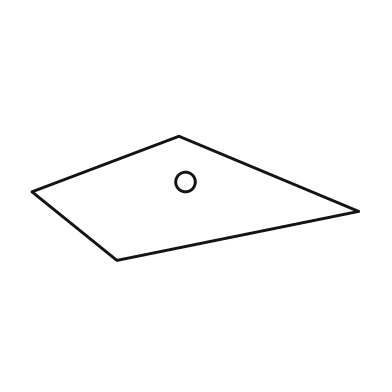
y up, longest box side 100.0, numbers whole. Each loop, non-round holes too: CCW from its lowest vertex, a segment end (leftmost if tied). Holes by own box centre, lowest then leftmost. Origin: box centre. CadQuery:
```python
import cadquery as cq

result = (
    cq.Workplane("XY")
    .moveTo(-24.0, -19.0)
    .lineTo(50.0, -4.0)
    .lineTo(-5.0, 19.0)
    .lineTo(-50.0, 2.0)
    .close()
    .moveTo(-3.0, 5.0)
    .circle(3.0)
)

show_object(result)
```